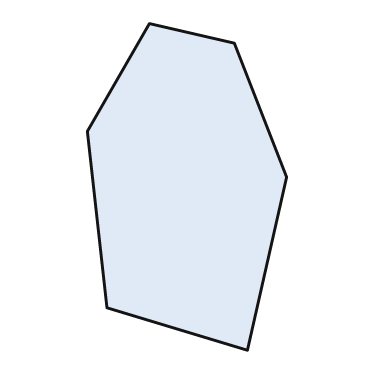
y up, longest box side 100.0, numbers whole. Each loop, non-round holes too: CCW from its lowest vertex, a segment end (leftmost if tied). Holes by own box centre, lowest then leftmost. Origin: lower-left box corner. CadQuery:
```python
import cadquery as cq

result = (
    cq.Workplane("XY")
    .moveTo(49.0, 0.0)
    .lineTo(61.0, 53.0)
    .lineTo(45.0, 94.0)
    .lineTo(19.0, 100.0)
    .lineTo(0.0, 67.0)
    .lineTo(6.0, 13.0)
    .close()
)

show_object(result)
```